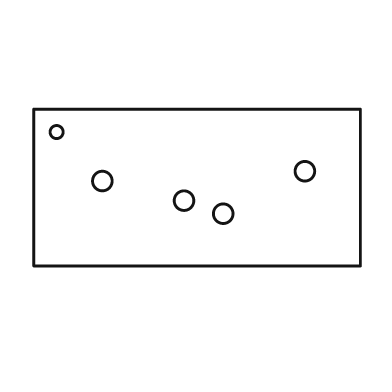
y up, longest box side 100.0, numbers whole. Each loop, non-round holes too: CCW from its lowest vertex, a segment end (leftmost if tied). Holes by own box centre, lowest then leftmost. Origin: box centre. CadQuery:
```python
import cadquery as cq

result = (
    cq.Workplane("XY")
    .moveTo(-50.0, -24.0)
    .lineTo(50.0, -24.0)
    .lineTo(50.0, 24.0)
    .lineTo(-50.0, 24.0)
    .close()
    .moveTo(8.0, -8.0)
    .circle(3.0)
    .moveTo(-4.0, -4.0)
    .circle(3.0)
    .moveTo(-29.0, 2.0)
    .circle(3.0)
    .moveTo(33.0, 5.0)
    .circle(3.0)
    .moveTo(-43.0, 17.0)
    .circle(2.0)
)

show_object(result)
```